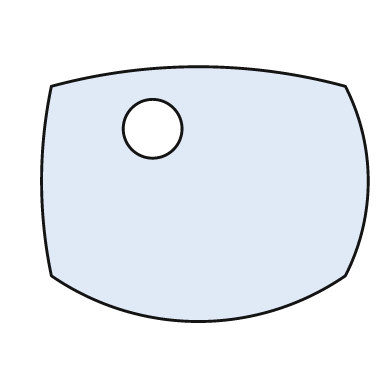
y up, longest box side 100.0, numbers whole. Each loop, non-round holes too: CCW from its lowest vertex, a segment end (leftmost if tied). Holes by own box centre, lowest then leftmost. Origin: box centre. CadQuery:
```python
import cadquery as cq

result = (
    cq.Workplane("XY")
    .moveTo(-47.0, -25.0)
    .threePointArc((-2.0, -39.0), (43.0, -25.0))
    .threePointArc((50.0, 4.0), (43.0, 33.0))
    .threePointArc((-2.0, 39.0), (-47.0, 33.0))
    .threePointArc((-50.0, 4.0), (-47.0, -25.0))
    .close()
    .moveTo(-16.0, 20.0)
    .circle(9.0)
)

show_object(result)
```